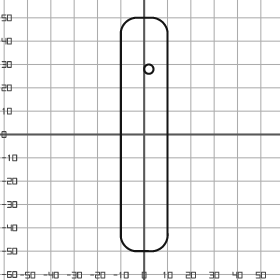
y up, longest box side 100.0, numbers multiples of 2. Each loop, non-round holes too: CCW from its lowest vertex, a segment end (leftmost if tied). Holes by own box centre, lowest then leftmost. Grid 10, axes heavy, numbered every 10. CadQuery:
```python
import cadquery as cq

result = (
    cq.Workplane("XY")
    .moveTo(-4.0, -50.0)
    .lineTo(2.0, -50.0)
    .threePointArc((8.0, -48.0), (10.0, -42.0))
    .lineTo(10.0, 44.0)
    .threePointArc((8.0, 48.0), (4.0, 50.0))
    .lineTo(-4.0, 50.0)
    .threePointArc((-8.0, 48.0), (-10.0, 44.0))
    .lineTo(-10.0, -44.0)
    .threePointArc((-8.0, -48.0), (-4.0, -50.0))
    .close()
    .moveTo(2.0, 28.0)
    .circle(2.0)
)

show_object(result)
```